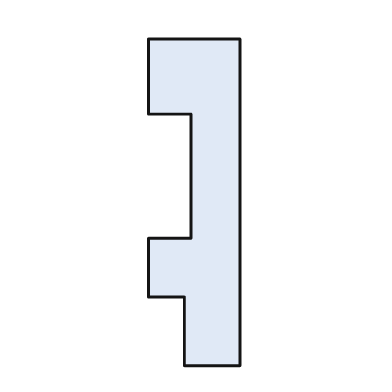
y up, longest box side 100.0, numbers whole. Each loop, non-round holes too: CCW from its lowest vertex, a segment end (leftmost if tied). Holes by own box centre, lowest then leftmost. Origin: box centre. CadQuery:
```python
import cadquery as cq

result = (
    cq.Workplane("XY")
    .moveTo(-3.0, -50.0)
    .lineTo(14.0, -50.0)
    .lineTo(14.0, 50.0)
    .lineTo(-14.0, 50.0)
    .lineTo(-14.0, 27.0)
    .lineTo(-1.0, 27.0)
    .lineTo(-1.0, -11.0)
    .lineTo(-14.0, -11.0)
    .lineTo(-14.0, -29.0)
    .lineTo(-3.0, -29.0)
    .close()
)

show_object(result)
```